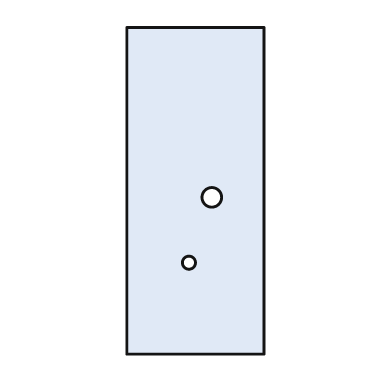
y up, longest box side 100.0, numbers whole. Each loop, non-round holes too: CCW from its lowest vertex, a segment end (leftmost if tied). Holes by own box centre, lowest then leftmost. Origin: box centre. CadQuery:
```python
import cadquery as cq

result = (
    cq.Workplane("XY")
    .moveTo(-21.0, -50.0)
    .lineTo(21.0, -50.0)
    .lineTo(21.0, 50.0)
    .lineTo(-21.0, 50.0)
    .close()
    .moveTo(-2.0, -22.0)
    .circle(2.0)
    .moveTo(5.0, -2.0)
    .circle(3.0)
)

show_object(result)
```